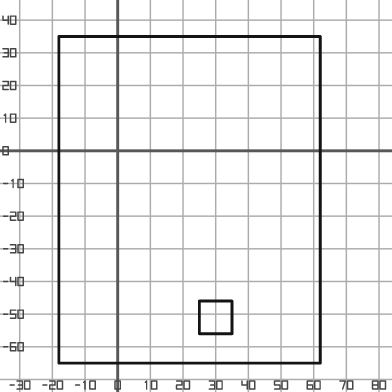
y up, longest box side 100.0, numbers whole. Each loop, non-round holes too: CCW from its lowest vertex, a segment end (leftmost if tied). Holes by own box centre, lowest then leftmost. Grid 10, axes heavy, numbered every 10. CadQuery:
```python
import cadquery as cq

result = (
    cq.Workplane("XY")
    .moveTo(-18.0, -65.0)
    .lineTo(62.0, -65.0)
    .lineTo(62.0, 35.0)
    .lineTo(-18.0, 35.0)
    .close()
    .moveTo(25.0, -56.0)
    .lineTo(35.0, -56.0)
    .lineTo(35.0, -46.0)
    .lineTo(25.0, -46.0)
    .close()
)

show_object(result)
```